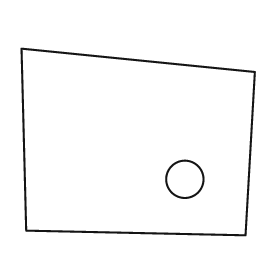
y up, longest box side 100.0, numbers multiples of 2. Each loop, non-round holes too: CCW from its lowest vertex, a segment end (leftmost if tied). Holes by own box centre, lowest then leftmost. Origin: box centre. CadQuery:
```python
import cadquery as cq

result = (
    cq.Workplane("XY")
    .moveTo(46.0, -40.0)
    .lineTo(50.0, 30.0)
    .lineTo(-50.0, 40.0)
    .lineTo(-48.0, -38.0)
    .close()
    .moveTo(20.0, -16.0)
    .circle(8.0)
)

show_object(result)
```